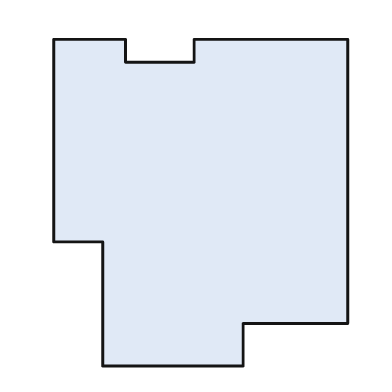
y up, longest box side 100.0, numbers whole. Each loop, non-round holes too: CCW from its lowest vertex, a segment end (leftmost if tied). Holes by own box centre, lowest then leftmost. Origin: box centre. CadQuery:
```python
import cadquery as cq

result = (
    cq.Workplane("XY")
    .moveTo(-30.0, -50.0)
    .lineTo(13.0, -50.0)
    .lineTo(13.0, -37.0)
    .lineTo(45.0, -37.0)
    .lineTo(45.0, 50.0)
    .lineTo(-2.0, 50.0)
    .lineTo(-2.0, 43.0)
    .lineTo(-23.0, 43.0)
    .lineTo(-23.0, 50.0)
    .lineTo(-45.0, 50.0)
    .lineTo(-45.0, -12.0)
    .lineTo(-30.0, -12.0)
    .close()
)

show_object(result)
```